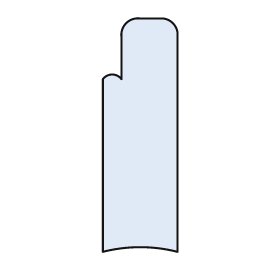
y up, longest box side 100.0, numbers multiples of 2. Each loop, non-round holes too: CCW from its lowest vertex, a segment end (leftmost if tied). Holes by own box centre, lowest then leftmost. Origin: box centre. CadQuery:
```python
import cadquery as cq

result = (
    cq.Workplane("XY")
    .moveTo(-16.0, -50.0)
    .threePointArc((0.0, -48.0), (16.0, -50.0))
    .lineTo(16.0, 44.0)
    .threePointArc((14.0, 48.0), (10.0, 50.0))
    .lineTo(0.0, 50.0)
    .threePointArc((-6.0, 48.0), (-8.0, 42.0))
    .lineTo(-8.0, 24.0)
    .threePointArc((-12.0, 26.0), (-16.0, 24.0))
    .close()
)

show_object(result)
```